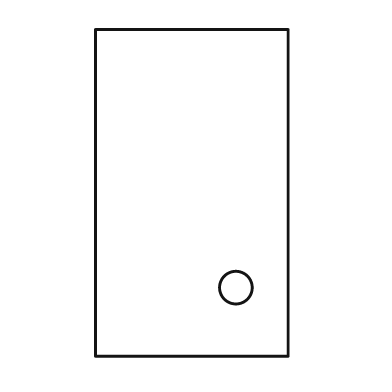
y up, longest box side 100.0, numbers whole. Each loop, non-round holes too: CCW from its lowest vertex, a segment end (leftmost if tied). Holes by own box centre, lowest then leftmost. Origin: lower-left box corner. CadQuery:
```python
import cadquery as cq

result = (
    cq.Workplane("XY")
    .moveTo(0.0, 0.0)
    .lineTo(59.0, 0.0)
    .lineTo(59.0, 100.0)
    .lineTo(0.0, 100.0)
    .close()
    .moveTo(43.0, 21.0)
    .circle(5.0)
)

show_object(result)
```